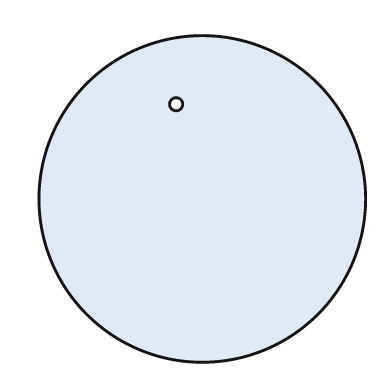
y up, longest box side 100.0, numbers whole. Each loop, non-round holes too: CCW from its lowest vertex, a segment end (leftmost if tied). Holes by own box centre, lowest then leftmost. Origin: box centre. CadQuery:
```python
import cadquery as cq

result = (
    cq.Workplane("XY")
    .moveTo(0.0, 0.0)
    .circle(50.0)
    .moveTo(-8.0, 29.0)
    .circle(2.0)
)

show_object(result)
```